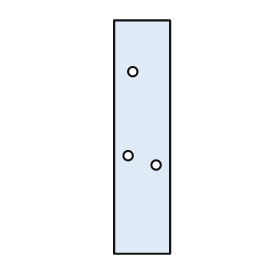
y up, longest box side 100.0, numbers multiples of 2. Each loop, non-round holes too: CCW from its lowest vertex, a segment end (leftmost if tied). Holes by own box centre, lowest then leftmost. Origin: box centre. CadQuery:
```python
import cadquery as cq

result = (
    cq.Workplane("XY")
    .moveTo(-12.0, -50.0)
    .lineTo(12.0, -50.0)
    .lineTo(12.0, 50.0)
    .lineTo(-12.0, 50.0)
    .close()
    .moveTo(6.0, -12.0)
    .circle(2.0)
    .moveTo(-6.0, -8.0)
    .circle(2.0)
    .moveTo(-4.0, 28.0)
    .circle(2.0)
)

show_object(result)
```